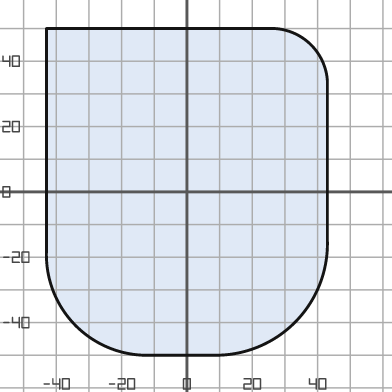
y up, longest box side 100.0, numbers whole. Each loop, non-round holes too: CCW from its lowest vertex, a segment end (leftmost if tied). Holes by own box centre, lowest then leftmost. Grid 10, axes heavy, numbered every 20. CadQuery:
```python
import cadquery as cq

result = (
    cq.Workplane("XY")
    .moveTo(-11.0, -50.0)
    .lineTo(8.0, -50.0)
    .threePointArc((33.0, -40.0), (43.0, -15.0))
    .lineTo(43.0, 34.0)
    .threePointArc((38.0, 45.0), (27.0, 50.0))
    .lineTo(-43.0, 50.0)
    .lineTo(-43.0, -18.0)
    .threePointArc((-34.0, -41.0), (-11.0, -50.0))
    .close()
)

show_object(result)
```